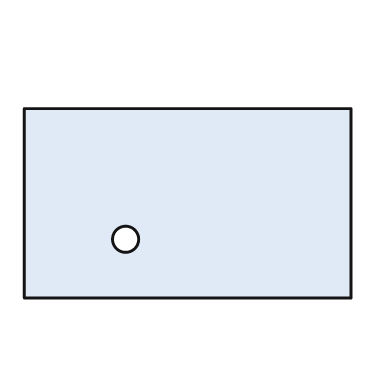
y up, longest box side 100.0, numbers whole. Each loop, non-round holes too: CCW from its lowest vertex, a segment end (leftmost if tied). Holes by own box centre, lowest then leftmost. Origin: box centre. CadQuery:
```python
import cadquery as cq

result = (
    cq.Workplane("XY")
    .moveTo(-50.0, -29.0)
    .lineTo(50.0, -29.0)
    .lineTo(50.0, 29.0)
    .lineTo(-50.0, 29.0)
    .close()
    .moveTo(-19.0, -11.0)
    .circle(4.0)
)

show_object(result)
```